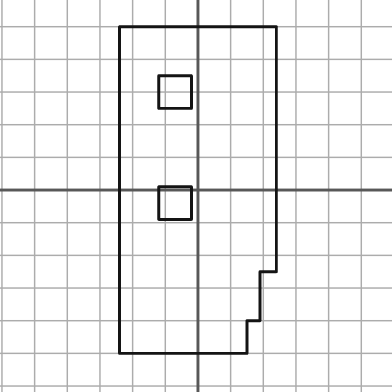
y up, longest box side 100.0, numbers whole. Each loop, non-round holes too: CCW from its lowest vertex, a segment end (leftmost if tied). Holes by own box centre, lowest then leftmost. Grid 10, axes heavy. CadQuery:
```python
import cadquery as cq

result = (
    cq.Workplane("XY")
    .moveTo(-24.0, -50.0)
    .lineTo(15.0, -50.0)
    .lineTo(15.0, -40.0)
    .lineTo(19.0, -40.0)
    .lineTo(19.0, -25.0)
    .lineTo(24.0, -25.0)
    .lineTo(24.0, 50.0)
    .lineTo(-24.0, 50.0)
    .close()
    .moveTo(-12.0, -9.0)
    .lineTo(-2.0, -9.0)
    .lineTo(-2.0, 1.0)
    .lineTo(-12.0, 1.0)
    .close()
    .moveTo(-12.0, 25.0)
    .lineTo(-2.0, 25.0)
    .lineTo(-2.0, 35.0)
    .lineTo(-12.0, 35.0)
    .close()
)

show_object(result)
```